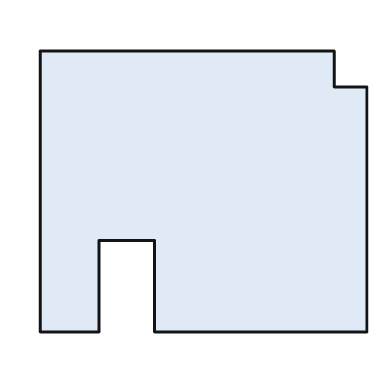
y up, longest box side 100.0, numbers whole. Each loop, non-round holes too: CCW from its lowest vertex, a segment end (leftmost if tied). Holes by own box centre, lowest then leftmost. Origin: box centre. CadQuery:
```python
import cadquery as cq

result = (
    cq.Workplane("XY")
    .moveTo(-50.0, -43.0)
    .lineTo(-32.0, -43.0)
    .lineTo(-32.0, -15.0)
    .lineTo(-15.0, -15.0)
    .lineTo(-15.0, -43.0)
    .lineTo(50.0, -43.0)
    .lineTo(50.0, 32.0)
    .lineTo(40.0, 32.0)
    .lineTo(40.0, 43.0)
    .lineTo(-50.0, 43.0)
    .close()
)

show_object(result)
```